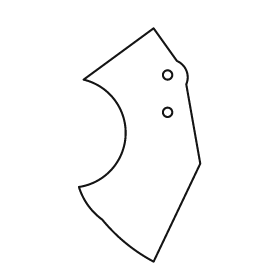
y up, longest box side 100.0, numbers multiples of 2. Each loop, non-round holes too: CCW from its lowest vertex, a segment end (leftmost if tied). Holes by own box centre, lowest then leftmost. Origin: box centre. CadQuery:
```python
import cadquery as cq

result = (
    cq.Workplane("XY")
    .moveTo(6.0, -50.0)
    .lineTo(26.0, -8.0)
    .lineTo(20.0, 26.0)
    .threePointArc((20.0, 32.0), (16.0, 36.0))
    .lineTo(6.0, 50.0)
    .lineTo(-24.0, 28.0)
    .threePointArc((-6.0, 4.0), (-26.0, -18.0))
    .threePointArc((-22.0, -26.0), (-16.0, -32.0))
    .threePointArc((-6.0, -42.0), (6.0, -50.0))
    .close()
    .moveTo(12.0, 14.0)
    .circle(2.0)
    .moveTo(12.0, 30.0)
    .circle(2.0)
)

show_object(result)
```